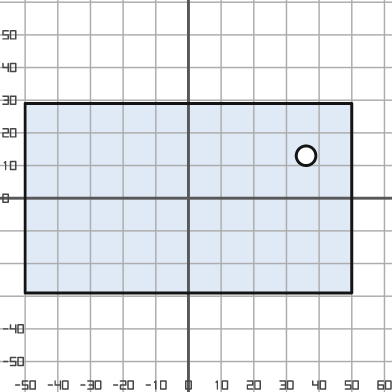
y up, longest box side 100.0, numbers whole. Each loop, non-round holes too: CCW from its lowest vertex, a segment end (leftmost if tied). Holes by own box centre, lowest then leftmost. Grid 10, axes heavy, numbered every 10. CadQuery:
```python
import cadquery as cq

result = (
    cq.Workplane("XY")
    .moveTo(-50.0, -29.0)
    .lineTo(50.0, -29.0)
    .lineTo(50.0, 29.0)
    .lineTo(-50.0, 29.0)
    .close()
    .moveTo(36.0, 13.0)
    .circle(3.0)
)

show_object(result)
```